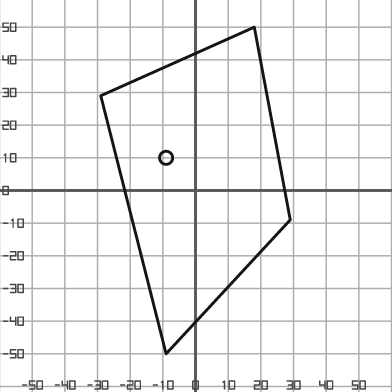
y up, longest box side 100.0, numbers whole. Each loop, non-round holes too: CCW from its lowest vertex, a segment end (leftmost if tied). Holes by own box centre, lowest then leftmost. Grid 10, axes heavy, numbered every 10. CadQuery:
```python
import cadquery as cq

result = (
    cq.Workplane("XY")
    .moveTo(-9.0, -50.0)
    .lineTo(29.0, -9.0)
    .lineTo(18.0, 50.0)
    .lineTo(-29.0, 29.0)
    .close()
    .moveTo(-9.0, 10.0)
    .circle(2.0)
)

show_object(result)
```